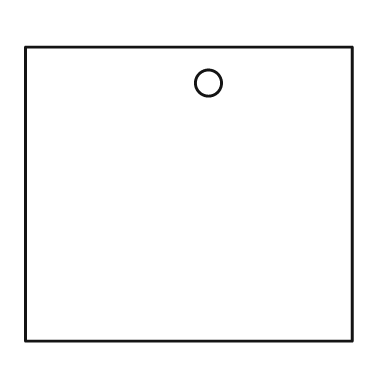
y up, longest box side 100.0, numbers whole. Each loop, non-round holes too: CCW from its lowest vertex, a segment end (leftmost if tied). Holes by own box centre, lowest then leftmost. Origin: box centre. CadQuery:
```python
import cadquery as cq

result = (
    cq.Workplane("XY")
    .moveTo(-50.0, -45.0)
    .lineTo(50.0, -45.0)
    .lineTo(50.0, 45.0)
    .lineTo(-50.0, 45.0)
    .close()
    .moveTo(6.0, 34.0)
    .circle(4.0)
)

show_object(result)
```